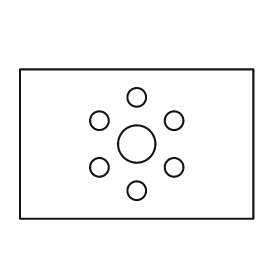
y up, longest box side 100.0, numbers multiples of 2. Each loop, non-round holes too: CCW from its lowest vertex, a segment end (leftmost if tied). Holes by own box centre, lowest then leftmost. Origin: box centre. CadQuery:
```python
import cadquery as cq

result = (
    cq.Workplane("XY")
    .moveTo(-50.0, -32.0)
    .lineTo(50.0, -32.0)
    .lineTo(50.0, 32.0)
    .lineTo(-50.0, 32.0)
    .close()
    .moveTo(0.0, -20.0)
    .circle(4.0)
    .moveTo(-16.0, -10.0)
    .circle(4.0)
    .moveTo(16.0, -10.0)
    .circle(4.0)
    .moveTo(0.0, 0.0)
    .circle(8.0)
    .moveTo(-16.0, 10.0)
    .circle(4.0)
    .moveTo(16.0, 10.0)
    .circle(4.0)
    .moveTo(0.0, 20.0)
    .circle(4.0)
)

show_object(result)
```